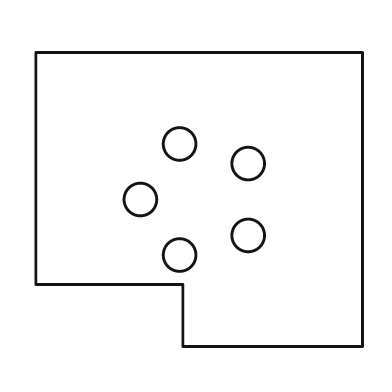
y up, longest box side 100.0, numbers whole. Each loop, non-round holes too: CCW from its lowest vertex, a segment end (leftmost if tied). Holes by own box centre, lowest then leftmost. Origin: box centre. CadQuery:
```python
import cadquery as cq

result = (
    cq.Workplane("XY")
    .moveTo(-5.0, -45.0)
    .lineTo(50.0, -45.0)
    .lineTo(50.0, 45.0)
    .lineTo(-50.0, 45.0)
    .lineTo(-50.0, -26.0)
    .lineTo(-5.0, -26.0)
    .close()
    .moveTo(-6.0, -17.0)
    .circle(5.0)
    .moveTo(15.0, -11.0)
    .circle(5.0)
    .moveTo(-18.0, 0.0)
    .circle(5.0)
    .moveTo(15.0, 11.0)
    .circle(5.0)
    .moveTo(-6.0, 17.0)
    .circle(5.0)
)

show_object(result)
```